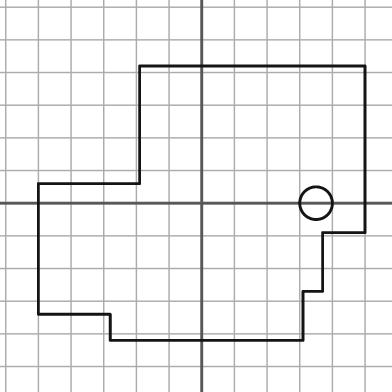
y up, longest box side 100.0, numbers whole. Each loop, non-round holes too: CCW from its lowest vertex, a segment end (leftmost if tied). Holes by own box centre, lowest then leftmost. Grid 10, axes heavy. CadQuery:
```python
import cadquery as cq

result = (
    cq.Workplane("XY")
    .moveTo(-28.0, -42.0)
    .lineTo(31.0, -42.0)
    .lineTo(31.0, -27.0)
    .lineTo(37.0, -27.0)
    .lineTo(37.0, -9.0)
    .lineTo(50.0, -9.0)
    .lineTo(50.0, 42.0)
    .lineTo(-19.0, 42.0)
    .lineTo(-19.0, 6.0)
    .lineTo(-50.0, 6.0)
    .lineTo(-50.0, -34.0)
    .lineTo(-28.0, -34.0)
    .close()
    .moveTo(35.0, 0.0)
    .circle(5.0)
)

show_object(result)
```